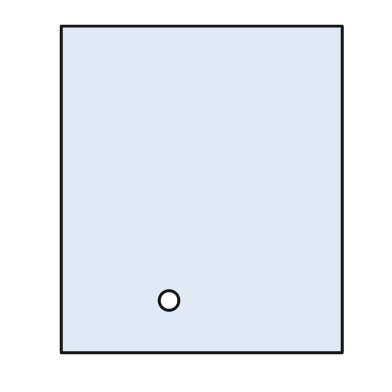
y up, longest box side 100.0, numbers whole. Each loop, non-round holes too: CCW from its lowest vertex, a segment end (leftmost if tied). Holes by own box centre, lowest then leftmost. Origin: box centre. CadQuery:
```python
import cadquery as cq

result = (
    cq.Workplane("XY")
    .moveTo(-43.0, -50.0)
    .lineTo(43.0, -50.0)
    .lineTo(43.0, 50.0)
    .lineTo(-43.0, 50.0)
    .close()
    .moveTo(-10.0, -34.0)
    .circle(3.0)
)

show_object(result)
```